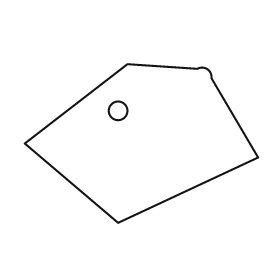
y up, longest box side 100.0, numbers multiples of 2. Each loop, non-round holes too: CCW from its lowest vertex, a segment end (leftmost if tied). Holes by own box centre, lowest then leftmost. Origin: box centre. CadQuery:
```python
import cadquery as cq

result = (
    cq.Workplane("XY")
    .moveTo(-10.0, -34.0)
    .lineTo(50.0, -6.0)
    .lineTo(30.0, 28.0)
    .threePointArc((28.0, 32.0), (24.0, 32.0))
    .lineTo(-6.0, 34.0)
    .lineTo(-50.0, 0.0)
    .close()
    .moveTo(-10.0, 14.0)
    .circle(4.0)
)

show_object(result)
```